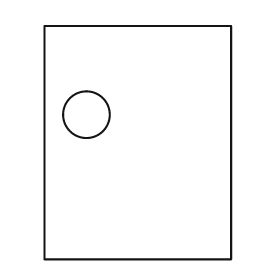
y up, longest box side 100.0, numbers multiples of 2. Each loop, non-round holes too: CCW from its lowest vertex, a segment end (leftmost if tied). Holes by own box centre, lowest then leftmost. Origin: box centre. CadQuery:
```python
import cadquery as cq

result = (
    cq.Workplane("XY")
    .moveTo(-40.0, -50.0)
    .lineTo(40.0, -50.0)
    .lineTo(40.0, 50.0)
    .lineTo(-40.0, 50.0)
    .close()
    .moveTo(-22.0, 12.0)
    .circle(10.0)
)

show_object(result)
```